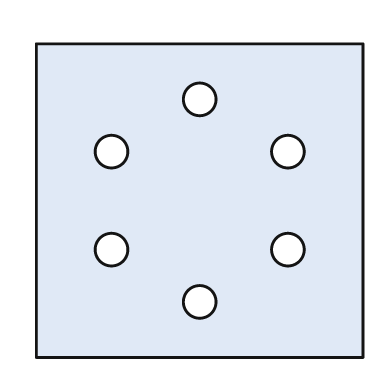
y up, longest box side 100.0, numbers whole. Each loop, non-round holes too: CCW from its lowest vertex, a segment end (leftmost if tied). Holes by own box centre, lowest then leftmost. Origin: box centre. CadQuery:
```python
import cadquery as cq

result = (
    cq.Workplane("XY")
    .moveTo(-50.0, -48.0)
    .lineTo(50.0, -48.0)
    .lineTo(50.0, 48.0)
    .lineTo(-50.0, 48.0)
    .close()
    .moveTo(0.0, -31.0)
    .circle(5.0)
    .moveTo(-27.0, -15.0)
    .circle(5.0)
    .moveTo(27.0, -15.0)
    .circle(5.0)
    .moveTo(-27.0, 15.0)
    .circle(5.0)
    .moveTo(27.0, 15.0)
    .circle(5.0)
    .moveTo(0.0, 31.0)
    .circle(5.0)
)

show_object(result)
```